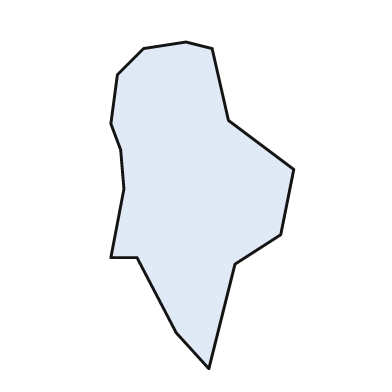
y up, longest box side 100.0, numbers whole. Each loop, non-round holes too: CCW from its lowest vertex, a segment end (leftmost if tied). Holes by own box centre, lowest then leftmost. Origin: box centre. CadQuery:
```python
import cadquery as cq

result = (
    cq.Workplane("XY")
    .moveTo(2.0, -50.0)
    .lineTo(10.0, -18.0)
    .lineTo(24.0, -9.0)
    .lineTo(28.0, 11.0)
    .lineTo(8.0, 26.0)
    .lineTo(3.0, 48.0)
    .lineTo(-5.0, 50.0)
    .lineTo(-18.0, 48.0)
    .lineTo(-26.0, 40.0)
    .lineTo(-28.0, 25.0)
    .lineTo(-25.0, 17.0)
    .lineTo(-24.0, 5.0)
    .lineTo(-28.0, -16.0)
    .lineTo(-20.0, -16.0)
    .lineTo(-8.0, -39.0)
    .close()
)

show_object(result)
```